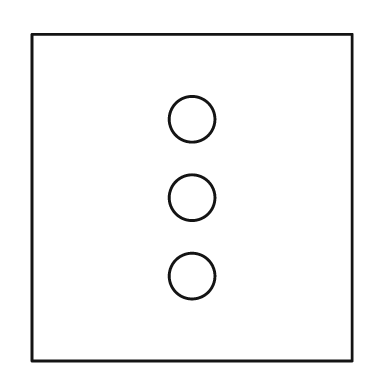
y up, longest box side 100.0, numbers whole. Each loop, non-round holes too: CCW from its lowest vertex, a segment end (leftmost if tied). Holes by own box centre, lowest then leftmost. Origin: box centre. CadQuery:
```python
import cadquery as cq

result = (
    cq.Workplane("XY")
    .moveTo(-49.0, -50.0)
    .lineTo(49.0, -50.0)
    .lineTo(49.0, 50.0)
    .lineTo(-49.0, 50.0)
    .close()
    .moveTo(0.0, -24.0)
    .circle(7.0)
    .moveTo(0.0, 0.0)
    .circle(7.0)
    .moveTo(0.0, 24.0)
    .circle(7.0)
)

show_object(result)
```